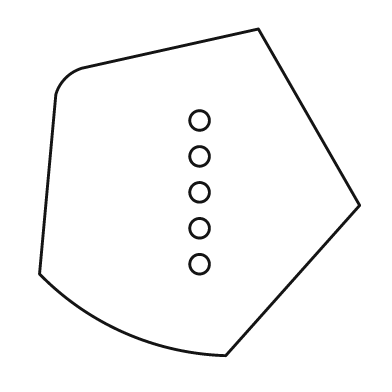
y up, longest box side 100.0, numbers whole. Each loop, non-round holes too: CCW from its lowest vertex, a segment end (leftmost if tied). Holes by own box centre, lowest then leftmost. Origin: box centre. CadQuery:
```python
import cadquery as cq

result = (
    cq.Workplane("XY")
    .moveTo(8.0, -50.0)
    .lineTo(49.0, -4.0)
    .lineTo(18.0, 50.0)
    .lineTo(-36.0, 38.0)
    .threePointArc((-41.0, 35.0), (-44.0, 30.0))
    .lineTo(-49.0, -25.0)
    .threePointArc((-23.0, -43.0), (8.0, -50.0))
    .close()
    .moveTo(0.0, -22.0)
    .circle(3.0)
    .moveTo(0.0, -11.0)
    .circle(3.0)
    .moveTo(0.0, 0.0)
    .circle(3.0)
    .moveTo(0.0, 11.0)
    .circle(3.0)
    .moveTo(0.0, 22.0)
    .circle(3.0)
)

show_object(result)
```